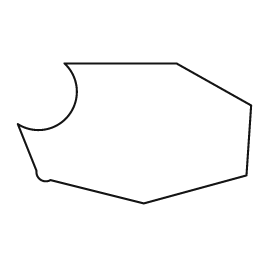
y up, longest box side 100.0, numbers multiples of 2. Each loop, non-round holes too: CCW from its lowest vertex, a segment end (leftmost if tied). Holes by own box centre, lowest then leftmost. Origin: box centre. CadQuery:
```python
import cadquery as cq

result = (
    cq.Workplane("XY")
    .moveTo(4.0, -30.0)
    .lineTo(48.0, -18.0)
    .lineTo(50.0, 12.0)
    .lineTo(18.0, 30.0)
    .lineTo(-30.0, 30.0)
    .threePointArc((-28.0, 8.0), (-50.0, 4.0))
    .lineTo(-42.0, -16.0)
    .threePointArc((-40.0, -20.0), (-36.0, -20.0))
    .close()
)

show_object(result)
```